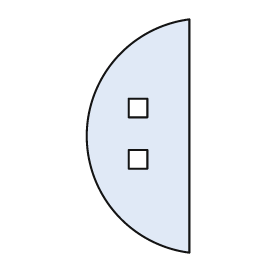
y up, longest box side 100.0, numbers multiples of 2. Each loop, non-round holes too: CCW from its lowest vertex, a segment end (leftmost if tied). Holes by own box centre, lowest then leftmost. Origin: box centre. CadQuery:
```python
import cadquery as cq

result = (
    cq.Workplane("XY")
    .moveTo(22.0, -50.0)
    .lineTo(22.0, 50.0)
    .threePointArc((-22.0, 0.0), (22.0, -50.0))
    .close()
    .moveTo(-4.0, -14.0)
    .lineTo(4.0, -14.0)
    .lineTo(4.0, -6.0)
    .lineTo(-4.0, -6.0)
    .close()
    .moveTo(-4.0, 8.0)
    .lineTo(4.0, 8.0)
    .lineTo(4.0, 16.0)
    .lineTo(-4.0, 16.0)
    .close()
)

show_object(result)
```